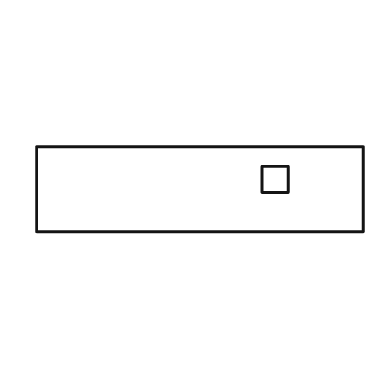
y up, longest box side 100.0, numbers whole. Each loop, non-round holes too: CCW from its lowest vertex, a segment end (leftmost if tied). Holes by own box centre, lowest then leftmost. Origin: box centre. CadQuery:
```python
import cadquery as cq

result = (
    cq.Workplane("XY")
    .moveTo(-50.0, -13.0)
    .lineTo(50.0, -13.0)
    .lineTo(50.0, 13.0)
    .lineTo(-50.0, 13.0)
    .close()
    .moveTo(19.0, -1.0)
    .lineTo(27.0, -1.0)
    .lineTo(27.0, 7.0)
    .lineTo(19.0, 7.0)
    .close()
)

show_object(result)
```